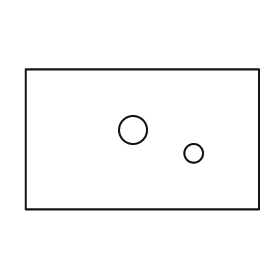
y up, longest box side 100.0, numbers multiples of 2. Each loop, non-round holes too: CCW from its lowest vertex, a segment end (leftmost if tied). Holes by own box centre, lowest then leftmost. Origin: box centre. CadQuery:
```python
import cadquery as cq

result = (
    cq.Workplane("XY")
    .moveTo(-50.0, -30.0)
    .lineTo(50.0, -30.0)
    .lineTo(50.0, 30.0)
    .lineTo(-50.0, 30.0)
    .close()
    .moveTo(22.0, -6.0)
    .circle(4.0)
    .moveTo(-4.0, 4.0)
    .circle(6.0)
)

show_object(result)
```